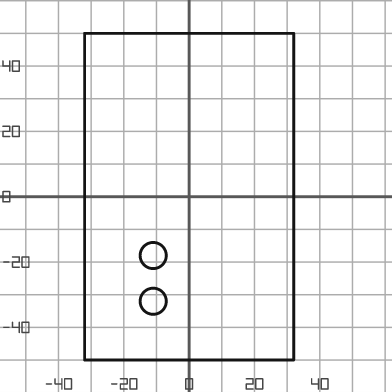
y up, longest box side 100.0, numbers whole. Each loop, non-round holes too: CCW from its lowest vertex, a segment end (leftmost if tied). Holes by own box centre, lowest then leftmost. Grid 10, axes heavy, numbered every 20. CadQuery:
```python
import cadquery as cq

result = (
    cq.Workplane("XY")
    .moveTo(-32.0, -50.0)
    .lineTo(32.0, -50.0)
    .lineTo(32.0, 50.0)
    .lineTo(-32.0, 50.0)
    .close()
    .moveTo(-11.0, -32.0)
    .circle(4.0)
    .moveTo(-11.0, -18.0)
    .circle(4.0)
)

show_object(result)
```